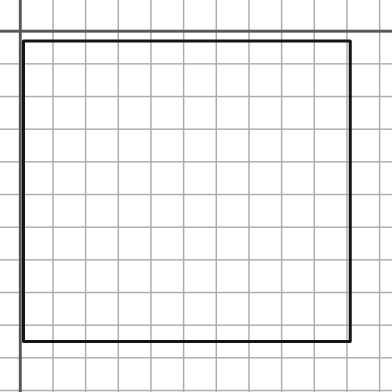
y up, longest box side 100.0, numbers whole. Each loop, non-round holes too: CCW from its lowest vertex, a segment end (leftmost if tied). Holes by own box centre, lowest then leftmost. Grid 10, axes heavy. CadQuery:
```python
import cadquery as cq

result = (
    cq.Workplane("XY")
    .moveTo(1.0, -95.0)
    .lineTo(101.0, -95.0)
    .lineTo(101.0, -3.0)
    .lineTo(1.0, -3.0)
    .close()
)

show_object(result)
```